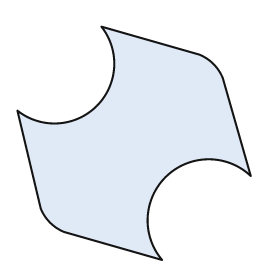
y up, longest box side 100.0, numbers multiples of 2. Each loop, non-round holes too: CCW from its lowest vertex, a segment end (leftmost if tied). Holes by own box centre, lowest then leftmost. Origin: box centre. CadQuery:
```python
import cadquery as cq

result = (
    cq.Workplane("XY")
    .moveTo(12.0, -50.0)
    .threePointArc((14.0, -14.0), (50.0, -14.0))
    .lineTo(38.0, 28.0)
    .threePointArc((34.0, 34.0), (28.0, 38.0))
    .lineTo(-14.0, 50.0)
    .threePointArc((-16.0, 16.0), (-50.0, 14.0))
    .lineTo(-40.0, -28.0)
    .threePointArc((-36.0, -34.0), (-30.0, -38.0))
    .close()
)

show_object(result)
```